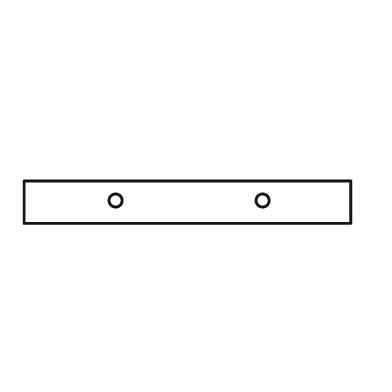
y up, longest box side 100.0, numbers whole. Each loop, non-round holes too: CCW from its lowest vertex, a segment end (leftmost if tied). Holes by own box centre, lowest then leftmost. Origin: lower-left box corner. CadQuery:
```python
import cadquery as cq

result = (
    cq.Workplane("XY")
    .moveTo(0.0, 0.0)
    .lineTo(100.0, 0.0)
    .lineTo(100.0, 13.0)
    .lineTo(0.0, 13.0)
    .close()
    .moveTo(28.0, 7.0)
    .circle(2.0)
    .moveTo(73.0, 7.0)
    .circle(2.0)
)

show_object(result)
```